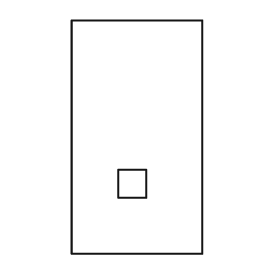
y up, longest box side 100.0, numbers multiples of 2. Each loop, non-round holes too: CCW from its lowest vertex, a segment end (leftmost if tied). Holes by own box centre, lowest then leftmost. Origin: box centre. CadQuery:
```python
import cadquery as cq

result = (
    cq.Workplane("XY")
    .moveTo(-28.0, -50.0)
    .lineTo(28.0, -50.0)
    .lineTo(28.0, 50.0)
    .lineTo(-28.0, 50.0)
    .close()
    .moveTo(-8.0, -26.0)
    .lineTo(4.0, -26.0)
    .lineTo(4.0, -14.0)
    .lineTo(-8.0, -14.0)
    .close()
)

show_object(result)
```